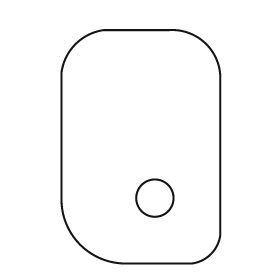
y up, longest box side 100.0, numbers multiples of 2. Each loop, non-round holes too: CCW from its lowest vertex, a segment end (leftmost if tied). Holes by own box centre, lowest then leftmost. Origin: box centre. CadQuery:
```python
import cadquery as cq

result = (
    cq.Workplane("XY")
    .moveTo(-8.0, -50.0)
    .lineTo(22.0, -50.0)
    .threePointArc((30.0, -46.0), (34.0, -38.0))
    .lineTo(34.0, 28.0)
    .threePointArc((28.0, 44.0), (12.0, 50.0))
    .lineTo(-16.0, 50.0)
    .threePointArc((-28.0, 44.0), (-34.0, 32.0))
    .lineTo(-34.0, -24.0)
    .threePointArc((-26.0, -42.0), (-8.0, -50.0))
    .close()
    .moveTo(6.0, -22.0)
    .circle(8.0)
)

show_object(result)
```